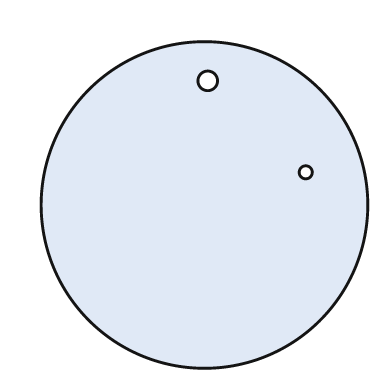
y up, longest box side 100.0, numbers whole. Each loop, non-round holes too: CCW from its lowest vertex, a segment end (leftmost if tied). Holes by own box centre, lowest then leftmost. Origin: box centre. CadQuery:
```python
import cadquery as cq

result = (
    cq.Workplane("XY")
    .moveTo(0.0, 0.0)
    .circle(50.0)
    .moveTo(31.0, 10.0)
    .circle(2.0)
    .moveTo(1.0, 38.0)
    .circle(3.0)
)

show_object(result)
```